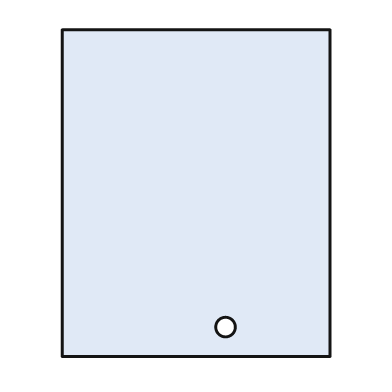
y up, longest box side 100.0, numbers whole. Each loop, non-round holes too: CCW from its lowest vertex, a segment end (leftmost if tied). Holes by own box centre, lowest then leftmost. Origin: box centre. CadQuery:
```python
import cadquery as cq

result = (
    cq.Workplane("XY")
    .moveTo(-41.0, -50.0)
    .lineTo(41.0, -50.0)
    .lineTo(41.0, 50.0)
    .lineTo(-41.0, 50.0)
    .close()
    .moveTo(9.0, -41.0)
    .circle(3.0)
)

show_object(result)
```